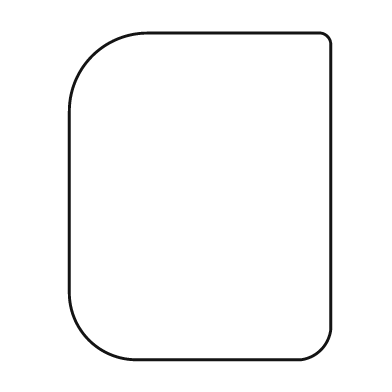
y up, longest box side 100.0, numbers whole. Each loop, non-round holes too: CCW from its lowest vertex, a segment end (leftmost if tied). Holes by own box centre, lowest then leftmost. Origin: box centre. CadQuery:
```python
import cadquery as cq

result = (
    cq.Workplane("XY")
    .moveTo(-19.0, -50.0)
    .lineTo(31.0, -50.0)
    .threePointArc((37.0, -47.0), (40.0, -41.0))
    .lineTo(40.0, 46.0)
    .threePointArc((39.0, 49.0), (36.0, 50.0))
    .lineTo(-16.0, 50.0)
    .threePointArc((-33.0, 43.0), (-40.0, 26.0))
    .lineTo(-40.0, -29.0)
    .threePointArc((-34.0, -44.0), (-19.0, -50.0))
    .close()
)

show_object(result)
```